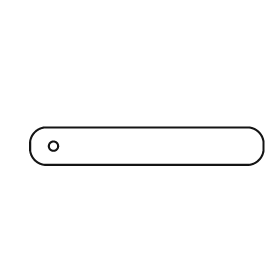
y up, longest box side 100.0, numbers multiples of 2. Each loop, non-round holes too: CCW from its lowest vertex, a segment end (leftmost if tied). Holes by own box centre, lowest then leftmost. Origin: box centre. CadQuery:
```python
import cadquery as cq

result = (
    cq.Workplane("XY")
    .moveTo(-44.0, -8.0)
    .lineTo(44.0, -8.0)
    .threePointArc((48.0, -6.0), (50.0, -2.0))
    .lineTo(50.0, 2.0)
    .threePointArc((48.0, 6.0), (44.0, 8.0))
    .lineTo(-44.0, 8.0)
    .threePointArc((-48.0, 6.0), (-50.0, 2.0))
    .lineTo(-50.0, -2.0)
    .threePointArc((-48.0, -6.0), (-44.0, -8.0))
    .close()
    .moveTo(-40.0, 0.0)
    .circle(2.0)
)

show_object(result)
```